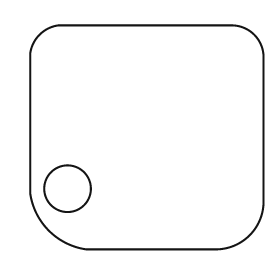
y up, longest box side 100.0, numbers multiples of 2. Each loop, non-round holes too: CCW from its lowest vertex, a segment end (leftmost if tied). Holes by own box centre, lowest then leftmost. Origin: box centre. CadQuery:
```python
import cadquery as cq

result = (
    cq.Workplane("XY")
    .moveTo(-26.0, -48.0)
    .lineTo(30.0, -48.0)
    .threePointArc((44.0, -42.0), (50.0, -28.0))
    .lineTo(50.0, 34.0)
    .threePointArc((46.0, 44.0), (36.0, 48.0))
    .lineTo(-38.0, 48.0)
    .threePointArc((-46.0, 44.0), (-50.0, 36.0))
    .lineTo(-50.0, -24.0)
    .threePointArc((-42.0, -40.0), (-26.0, -48.0))
    .close()
    .moveTo(-34.0, -22.0)
    .circle(10.0)
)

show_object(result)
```